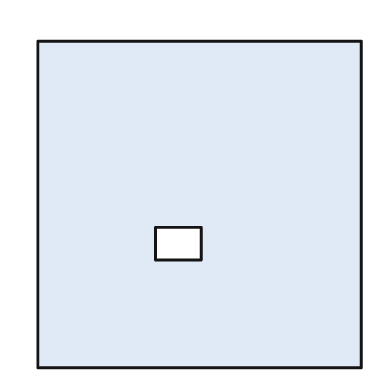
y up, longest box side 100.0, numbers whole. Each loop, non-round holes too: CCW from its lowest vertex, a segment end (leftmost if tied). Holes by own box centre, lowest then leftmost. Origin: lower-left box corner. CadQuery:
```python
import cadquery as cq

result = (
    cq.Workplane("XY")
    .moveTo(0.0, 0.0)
    .lineTo(99.0, 0.0)
    .lineTo(99.0, 100.0)
    .lineTo(0.0, 100.0)
    .close()
    .moveTo(36.0, 33.0)
    .lineTo(50.0, 33.0)
    .lineTo(50.0, 43.0)
    .lineTo(36.0, 43.0)
    .close()
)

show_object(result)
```